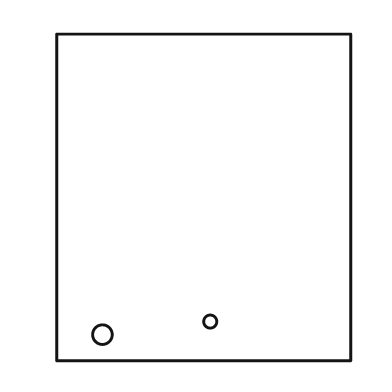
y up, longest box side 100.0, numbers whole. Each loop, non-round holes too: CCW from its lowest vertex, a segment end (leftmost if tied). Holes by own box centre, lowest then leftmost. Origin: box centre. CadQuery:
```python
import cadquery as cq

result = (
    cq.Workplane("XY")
    .moveTo(-45.0, -50.0)
    .lineTo(45.0, -50.0)
    .lineTo(45.0, 50.0)
    .lineTo(-45.0, 50.0)
    .close()
    .moveTo(-31.0, -42.0)
    .circle(3.0)
    .moveTo(2.0, -38.0)
    .circle(2.0)
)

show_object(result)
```